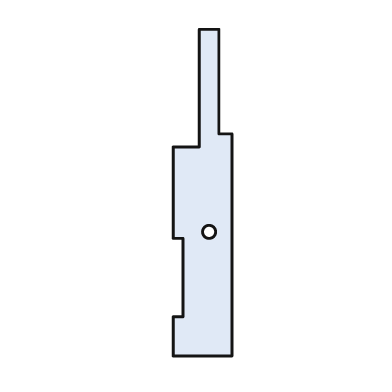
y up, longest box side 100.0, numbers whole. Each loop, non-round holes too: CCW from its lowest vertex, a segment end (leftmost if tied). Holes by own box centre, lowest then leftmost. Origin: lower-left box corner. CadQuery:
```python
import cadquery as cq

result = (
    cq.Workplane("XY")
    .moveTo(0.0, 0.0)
    .lineTo(18.0, 0.0)
    .lineTo(18.0, 68.0)
    .lineTo(14.0, 68.0)
    .lineTo(14.0, 100.0)
    .lineTo(8.0, 100.0)
    .lineTo(8.0, 64.0)
    .lineTo(0.0, 64.0)
    .lineTo(0.0, 36.0)
    .lineTo(3.0, 36.0)
    .lineTo(3.0, 12.0)
    .lineTo(0.0, 12.0)
    .close()
    .moveTo(11.0, 38.0)
    .circle(2.0)
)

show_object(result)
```